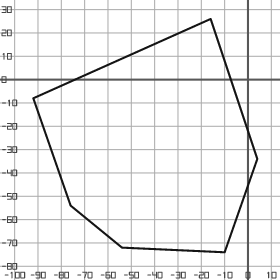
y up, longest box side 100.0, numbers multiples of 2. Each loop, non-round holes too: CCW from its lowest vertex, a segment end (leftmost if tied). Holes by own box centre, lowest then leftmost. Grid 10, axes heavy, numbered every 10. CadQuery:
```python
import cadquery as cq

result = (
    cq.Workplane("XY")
    .moveTo(-10.0, -74.0)
    .lineTo(4.0, -34.0)
    .lineTo(-16.0, 26.0)
    .lineTo(-92.0, -8.0)
    .lineTo(-76.0, -54.0)
    .lineTo(-54.0, -72.0)
    .close()
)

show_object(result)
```